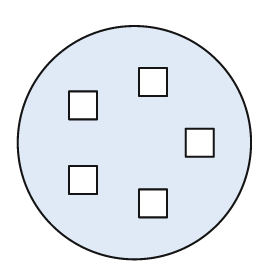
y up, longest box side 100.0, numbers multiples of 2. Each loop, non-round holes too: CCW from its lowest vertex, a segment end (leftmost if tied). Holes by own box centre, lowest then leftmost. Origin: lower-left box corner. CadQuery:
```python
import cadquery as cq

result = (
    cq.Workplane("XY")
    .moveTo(50.0, 50.0)
    .circle(50.0)
    .moveTo(52.0, 18.0)
    .lineTo(64.0, 18.0)
    .lineTo(64.0, 30.0)
    .lineTo(52.0, 30.0)
    .close()
    .moveTo(22.0, 28.0)
    .lineTo(34.0, 28.0)
    .lineTo(34.0, 40.0)
    .lineTo(22.0, 40.0)
    .close()
    .moveTo(72.0, 44.0)
    .lineTo(84.0, 44.0)
    .lineTo(84.0, 56.0)
    .lineTo(72.0, 56.0)
    .close()
    .moveTo(22.0, 60.0)
    .lineTo(34.0, 60.0)
    .lineTo(34.0, 72.0)
    .lineTo(22.0, 72.0)
    .close()
    .moveTo(52.0, 70.0)
    .lineTo(64.0, 70.0)
    .lineTo(64.0, 82.0)
    .lineTo(52.0, 82.0)
    .close()
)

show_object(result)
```